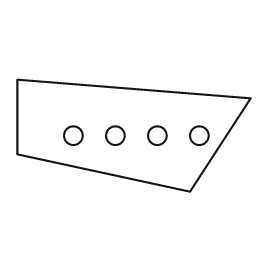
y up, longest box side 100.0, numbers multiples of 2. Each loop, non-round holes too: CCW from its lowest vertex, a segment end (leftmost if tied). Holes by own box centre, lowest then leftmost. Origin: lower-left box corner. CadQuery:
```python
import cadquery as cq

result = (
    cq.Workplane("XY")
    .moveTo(74.0, 0.0)
    .lineTo(100.0, 40.0)
    .lineTo(0.0, 48.0)
    .lineTo(0.0, 16.0)
    .close()
    .moveTo(24.0, 24.0)
    .circle(4.0)
    .moveTo(42.0, 24.0)
    .circle(4.0)
    .moveTo(60.0, 24.0)
    .circle(4.0)
    .moveTo(78.0, 24.0)
    .circle(4.0)
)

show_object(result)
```